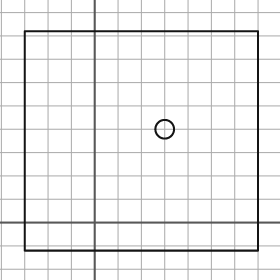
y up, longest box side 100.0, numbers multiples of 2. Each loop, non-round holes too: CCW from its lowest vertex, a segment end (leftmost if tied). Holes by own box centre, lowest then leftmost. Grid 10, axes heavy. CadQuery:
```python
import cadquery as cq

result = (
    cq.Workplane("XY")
    .moveTo(-30.0, -12.0)
    .lineTo(70.0, -12.0)
    .lineTo(70.0, 82.0)
    .lineTo(-30.0, 82.0)
    .close()
    .moveTo(30.0, 40.0)
    .circle(4.0)
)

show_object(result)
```